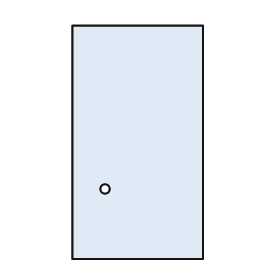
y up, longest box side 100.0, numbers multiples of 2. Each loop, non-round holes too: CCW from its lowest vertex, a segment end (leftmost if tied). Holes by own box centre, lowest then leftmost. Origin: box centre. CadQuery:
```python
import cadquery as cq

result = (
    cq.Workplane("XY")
    .moveTo(-28.0, -50.0)
    .lineTo(28.0, -50.0)
    .lineTo(28.0, 50.0)
    .lineTo(-28.0, 50.0)
    .close()
    .moveTo(-14.0, -20.0)
    .circle(2.0)
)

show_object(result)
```